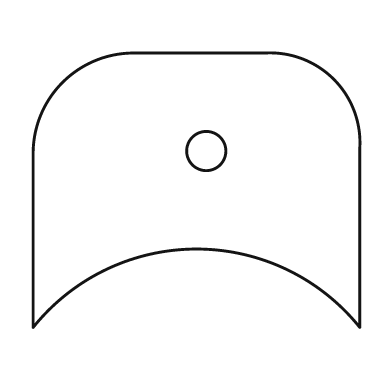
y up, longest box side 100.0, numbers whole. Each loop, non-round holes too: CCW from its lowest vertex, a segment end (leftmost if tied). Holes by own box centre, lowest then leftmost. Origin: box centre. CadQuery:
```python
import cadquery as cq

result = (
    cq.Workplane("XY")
    .moveTo(-50.0, -42.0)
    .threePointArc((0.0, -18.0), (50.0, -42.0))
    .lineTo(50.0, 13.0)
    .threePointArc((42.0, 34.0), (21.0, 42.0))
    .lineTo(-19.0, 42.0)
    .threePointArc((-41.0, 33.0), (-50.0, 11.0))
    .close()
    .moveTo(3.0, 12.0)
    .circle(6.0)
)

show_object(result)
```